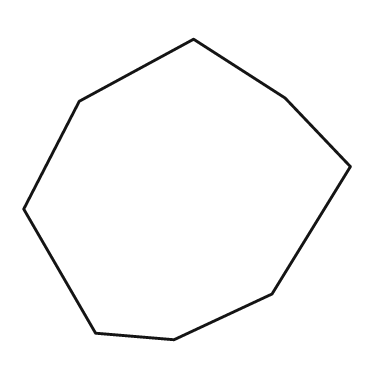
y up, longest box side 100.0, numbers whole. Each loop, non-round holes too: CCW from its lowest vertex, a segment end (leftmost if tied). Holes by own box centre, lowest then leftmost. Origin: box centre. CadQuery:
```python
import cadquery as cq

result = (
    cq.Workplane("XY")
    .moveTo(-4.0, -46.0)
    .lineTo(26.0, -32.0)
    .lineTo(50.0, 7.0)
    .lineTo(30.0, 28.0)
    .lineTo(2.0, 46.0)
    .lineTo(-33.0, 27.0)
    .lineTo(-50.0, -6.0)
    .lineTo(-28.0, -44.0)
    .close()
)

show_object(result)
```